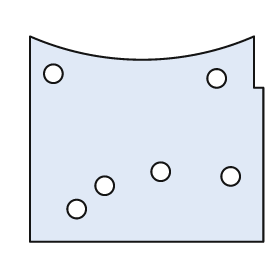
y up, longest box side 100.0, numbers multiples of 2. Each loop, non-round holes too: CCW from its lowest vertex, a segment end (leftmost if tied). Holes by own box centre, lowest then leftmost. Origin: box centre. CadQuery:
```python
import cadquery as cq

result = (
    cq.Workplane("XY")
    .moveTo(-50.0, -44.0)
    .lineTo(50.0, -44.0)
    .lineTo(50.0, 22.0)
    .lineTo(46.0, 22.0)
    .lineTo(46.0, 44.0)
    .threePointArc((-2.0, 34.0), (-50.0, 44.0))
    .close()
    .moveTo(-30.0, -30.0)
    .circle(4.0)
    .moveTo(-18.0, -20.0)
    .circle(4.0)
    .moveTo(36.0, -16.0)
    .circle(4.0)
    .moveTo(6.0, -14.0)
    .circle(4.0)
    .moveTo(30.0, 26.0)
    .circle(4.0)
    .moveTo(-40.0, 28.0)
    .circle(4.0)
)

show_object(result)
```